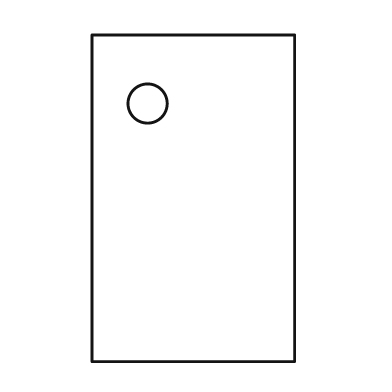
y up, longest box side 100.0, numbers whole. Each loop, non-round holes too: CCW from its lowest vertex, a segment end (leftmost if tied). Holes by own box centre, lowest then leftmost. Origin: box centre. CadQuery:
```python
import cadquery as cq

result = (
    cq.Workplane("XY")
    .moveTo(-31.0, -50.0)
    .lineTo(31.0, -50.0)
    .lineTo(31.0, 50.0)
    .lineTo(-31.0, 50.0)
    .close()
    .moveTo(-14.0, 29.0)
    .circle(6.0)
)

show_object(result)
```